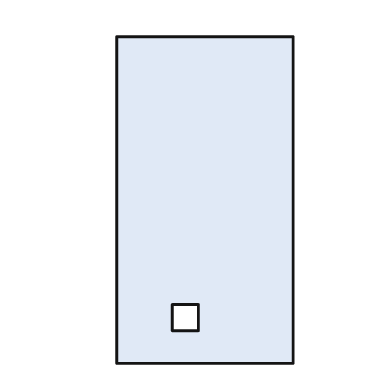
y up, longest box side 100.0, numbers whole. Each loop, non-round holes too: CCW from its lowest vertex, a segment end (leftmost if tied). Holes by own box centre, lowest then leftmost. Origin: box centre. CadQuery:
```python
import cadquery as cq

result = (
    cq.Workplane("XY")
    .moveTo(-27.0, -50.0)
    .lineTo(27.0, -50.0)
    .lineTo(27.0, 50.0)
    .lineTo(-27.0, 50.0)
    .close()
    .moveTo(-10.0, -40.0)
    .lineTo(-2.0, -40.0)
    .lineTo(-2.0, -32.0)
    .lineTo(-10.0, -32.0)
    .close()
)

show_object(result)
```